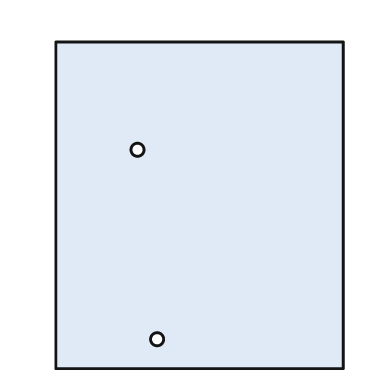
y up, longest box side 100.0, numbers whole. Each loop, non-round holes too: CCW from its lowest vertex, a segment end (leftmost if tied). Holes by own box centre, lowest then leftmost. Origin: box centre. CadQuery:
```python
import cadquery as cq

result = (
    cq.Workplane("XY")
    .moveTo(-44.0, -50.0)
    .lineTo(44.0, -50.0)
    .lineTo(44.0, 50.0)
    .lineTo(-44.0, 50.0)
    .close()
    .moveTo(-13.0, -41.0)
    .circle(2.0)
    .moveTo(-19.0, 17.0)
    .circle(2.0)
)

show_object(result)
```